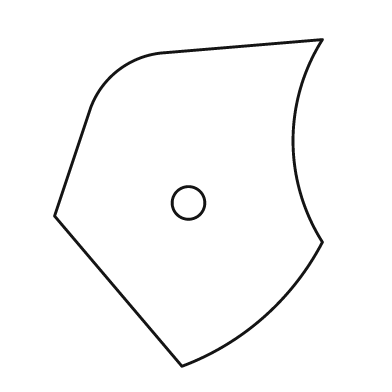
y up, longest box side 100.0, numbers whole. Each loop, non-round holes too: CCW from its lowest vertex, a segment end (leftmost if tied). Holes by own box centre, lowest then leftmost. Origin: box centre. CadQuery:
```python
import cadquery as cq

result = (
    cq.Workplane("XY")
    .moveTo(-2.0, -50.0)
    .threePointArc((23.0, -35.0), (41.0, -12.0))
    .threePointArc((32.0, 19.0), (41.0, 50.0))
    .lineTo(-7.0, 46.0)
    .threePointArc((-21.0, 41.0), (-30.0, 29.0))
    .lineTo(-41.0, -4.0)
    .close()
    .moveTo(0.0, 0.0)
    .circle(5.0)
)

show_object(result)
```